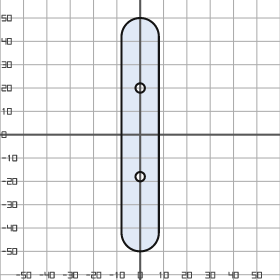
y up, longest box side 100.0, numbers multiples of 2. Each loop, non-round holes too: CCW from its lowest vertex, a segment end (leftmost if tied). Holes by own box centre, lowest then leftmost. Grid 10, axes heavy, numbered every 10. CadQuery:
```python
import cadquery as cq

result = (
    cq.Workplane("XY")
    .moveTo(-8.0, -42.0)
    .threePointArc((0.0, -50.0), (8.0, -42.0))
    .lineTo(8.0, 42.0)
    .threePointArc((0.0, 50.0), (-8.0, 42.0))
    .close()
    .moveTo(0.0, -18.0)
    .circle(2.0)
    .moveTo(0.0, 20.0)
    .circle(2.0)
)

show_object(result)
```